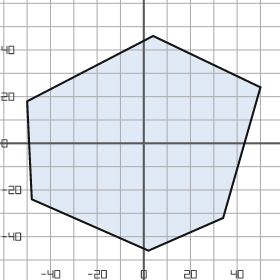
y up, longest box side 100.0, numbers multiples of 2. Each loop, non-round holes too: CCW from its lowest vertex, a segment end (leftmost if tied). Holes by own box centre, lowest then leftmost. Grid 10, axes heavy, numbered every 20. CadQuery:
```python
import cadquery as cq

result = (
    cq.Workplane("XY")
    .moveTo(2.0, -46.0)
    .lineTo(34.0, -32.0)
    .lineTo(50.0, 24.0)
    .lineTo(4.0, 46.0)
    .lineTo(-50.0, 18.0)
    .lineTo(-48.0, -24.0)
    .close()
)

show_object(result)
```